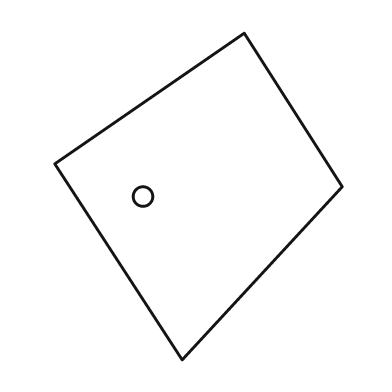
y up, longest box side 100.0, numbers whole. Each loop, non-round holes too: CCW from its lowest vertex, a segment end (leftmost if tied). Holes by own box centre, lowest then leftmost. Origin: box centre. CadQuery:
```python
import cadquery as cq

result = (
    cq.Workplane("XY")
    .moveTo(-5.0, -50.0)
    .lineTo(44.0, 3.0)
    .lineTo(14.0, 50.0)
    .lineTo(-44.0, 10.0)
    .close()
    .moveTo(-17.0, 0.0)
    .circle(3.0)
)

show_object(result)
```